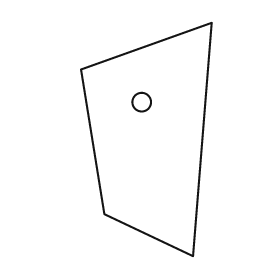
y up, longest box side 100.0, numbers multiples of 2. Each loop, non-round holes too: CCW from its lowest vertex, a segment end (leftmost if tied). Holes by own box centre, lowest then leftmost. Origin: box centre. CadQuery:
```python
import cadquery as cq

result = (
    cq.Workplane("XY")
    .moveTo(20.0, -50.0)
    .lineTo(28.0, 50.0)
    .lineTo(-28.0, 30.0)
    .lineTo(-18.0, -32.0)
    .close()
    .moveTo(-2.0, 16.0)
    .circle(4.0)
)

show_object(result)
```